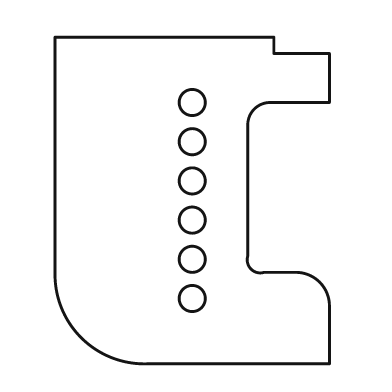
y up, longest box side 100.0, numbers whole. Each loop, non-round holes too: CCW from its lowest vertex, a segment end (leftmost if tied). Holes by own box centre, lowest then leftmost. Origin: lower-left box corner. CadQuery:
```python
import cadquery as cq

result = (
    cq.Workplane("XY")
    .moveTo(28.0, 0.0)
    .lineTo(84.0, 0.0)
    .lineTo(84.0, 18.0)
    .threePointArc((81.0, 25.0), (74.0, 28.0))
    .lineTo(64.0, 28.0)
    .threePointArc((60.0, 29.0), (59.0, 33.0))
    .lineTo(59.0, 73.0)
    .threePointArc((61.0, 78.0), (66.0, 80.0))
    .lineTo(84.0, 80.0)
    .lineTo(84.0, 95.0)
    .lineTo(67.0, 95.0)
    .lineTo(67.0, 100.0)
    .lineTo(0.0, 100.0)
    .lineTo(0.0, 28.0)
    .threePointArc((8.0, 8.0), (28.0, 0.0))
    .close()
    .moveTo(42.0, 20.0)
    .circle(4.0)
    .moveTo(42.0, 32.0)
    .circle(4.0)
    .moveTo(42.0, 44.0)
    .circle(4.0)
    .moveTo(42.0, 56.0)
    .circle(4.0)
    .moveTo(42.0, 68.0)
    .circle(4.0)
    .moveTo(42.0, 80.0)
    .circle(4.0)
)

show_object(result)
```